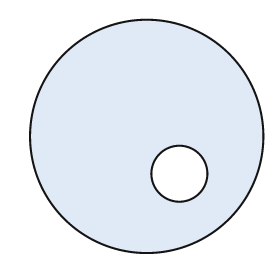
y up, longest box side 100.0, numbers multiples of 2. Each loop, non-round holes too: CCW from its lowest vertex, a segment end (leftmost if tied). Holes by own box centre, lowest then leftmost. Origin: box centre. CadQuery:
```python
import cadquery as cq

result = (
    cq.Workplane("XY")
    .moveTo(0.0, 0.0)
    .circle(50.0)
    .moveTo(14.0, -16.0)
    .circle(12.0)
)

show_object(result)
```